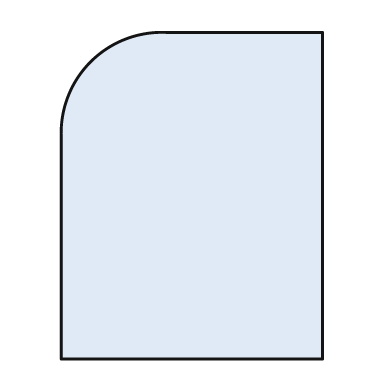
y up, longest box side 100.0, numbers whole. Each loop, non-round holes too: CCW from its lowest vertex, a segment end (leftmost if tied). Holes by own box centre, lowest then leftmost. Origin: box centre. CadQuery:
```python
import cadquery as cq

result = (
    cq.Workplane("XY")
    .moveTo(-40.0, -50.0)
    .lineTo(40.0, -50.0)
    .lineTo(40.0, 50.0)
    .lineTo(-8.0, 50.0)
    .threePointArc((-31.0, 41.0), (-40.0, 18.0))
    .close()
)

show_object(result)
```